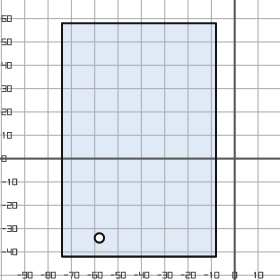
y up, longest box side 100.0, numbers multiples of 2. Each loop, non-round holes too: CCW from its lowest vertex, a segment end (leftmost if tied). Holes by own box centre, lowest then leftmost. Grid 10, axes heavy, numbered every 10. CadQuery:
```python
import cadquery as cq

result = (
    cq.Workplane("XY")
    .moveTo(-74.0, -42.0)
    .lineTo(-8.0, -42.0)
    .lineTo(-8.0, 58.0)
    .lineTo(-74.0, 58.0)
    .close()
    .moveTo(-58.0, -34.0)
    .circle(2.0)
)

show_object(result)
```